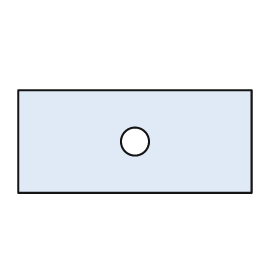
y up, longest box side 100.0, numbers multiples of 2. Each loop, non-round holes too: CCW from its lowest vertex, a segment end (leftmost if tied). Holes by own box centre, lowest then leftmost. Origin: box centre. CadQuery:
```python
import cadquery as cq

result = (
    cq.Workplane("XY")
    .moveTo(-50.0, -22.0)
    .lineTo(50.0, -22.0)
    .lineTo(50.0, 22.0)
    .lineTo(-50.0, 22.0)
    .close()
    .moveTo(0.0, 0.0)
    .circle(6.0)
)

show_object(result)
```